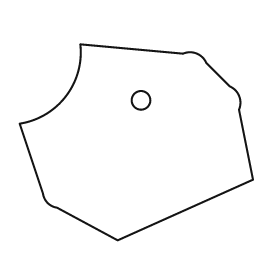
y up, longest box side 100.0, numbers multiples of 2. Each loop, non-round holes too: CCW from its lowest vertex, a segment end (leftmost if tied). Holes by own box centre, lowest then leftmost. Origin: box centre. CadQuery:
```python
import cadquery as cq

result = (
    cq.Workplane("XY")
    .moveTo(-8.0, -42.0)
    .lineTo(50.0, -16.0)
    .lineTo(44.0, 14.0)
    .threePointArc((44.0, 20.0), (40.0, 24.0))
    .lineTo(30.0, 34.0)
    .threePointArc((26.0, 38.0), (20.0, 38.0))
    .lineTo(-24.0, 42.0)
    .threePointArc((-30.0, 20.0), (-50.0, 8.0))
    .lineTo(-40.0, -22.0)
    .threePointArc((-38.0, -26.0), (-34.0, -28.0))
    .close()
    .moveTo(2.0, 18.0)
    .circle(4.0)
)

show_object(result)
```